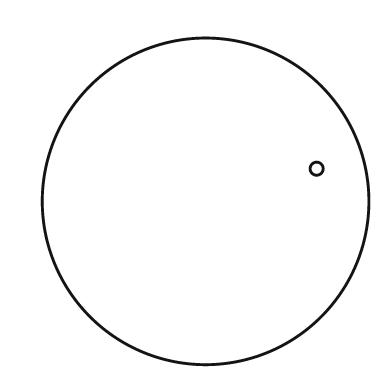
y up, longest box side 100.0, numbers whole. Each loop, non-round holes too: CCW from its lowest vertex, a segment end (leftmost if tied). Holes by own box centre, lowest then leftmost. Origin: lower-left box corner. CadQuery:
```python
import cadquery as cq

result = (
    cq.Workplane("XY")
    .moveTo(50.0, 50.0)
    .circle(50.0)
    .moveTo(84.0, 60.0)
    .circle(2.0)
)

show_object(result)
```